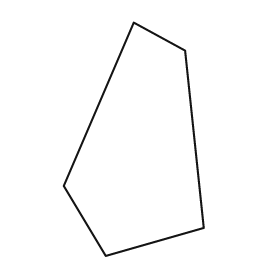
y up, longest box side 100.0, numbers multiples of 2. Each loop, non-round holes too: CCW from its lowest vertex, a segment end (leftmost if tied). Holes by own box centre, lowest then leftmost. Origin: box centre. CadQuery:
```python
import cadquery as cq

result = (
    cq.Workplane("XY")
    .moveTo(-12.0, -50.0)
    .lineTo(30.0, -38.0)
    .lineTo(22.0, 38.0)
    .lineTo(0.0, 50.0)
    .lineTo(-30.0, -20.0)
    .close()
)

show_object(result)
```